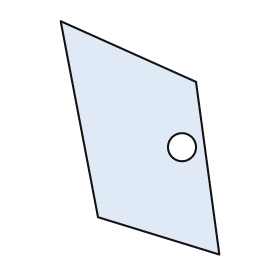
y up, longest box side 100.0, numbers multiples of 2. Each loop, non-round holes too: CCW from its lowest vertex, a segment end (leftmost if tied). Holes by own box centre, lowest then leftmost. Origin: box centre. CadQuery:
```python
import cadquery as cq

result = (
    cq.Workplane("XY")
    .moveTo(34.0, -50.0)
    .lineTo(24.0, 24.0)
    .lineTo(-34.0, 50.0)
    .lineTo(-18.0, -34.0)
    .close()
    .moveTo(18.0, -4.0)
    .circle(6.0)
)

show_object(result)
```